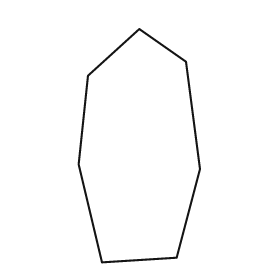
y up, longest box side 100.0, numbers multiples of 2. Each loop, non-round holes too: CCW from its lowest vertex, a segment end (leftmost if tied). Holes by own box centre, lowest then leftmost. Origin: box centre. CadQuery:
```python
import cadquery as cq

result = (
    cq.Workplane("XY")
    .moveTo(-16.0, -50.0)
    .lineTo(16.0, -48.0)
    .lineTo(26.0, -10.0)
    .lineTo(20.0, 36.0)
    .lineTo(0.0, 50.0)
    .lineTo(-22.0, 30.0)
    .lineTo(-26.0, -8.0)
    .close()
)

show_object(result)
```